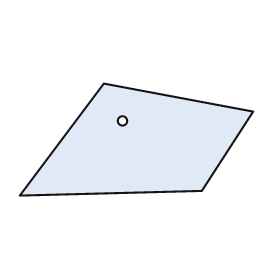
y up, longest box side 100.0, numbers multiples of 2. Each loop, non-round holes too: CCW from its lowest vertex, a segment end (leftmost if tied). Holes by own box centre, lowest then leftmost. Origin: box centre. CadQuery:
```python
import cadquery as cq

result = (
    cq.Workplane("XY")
    .moveTo(-50.0, -24.0)
    .lineTo(28.0, -22.0)
    .lineTo(50.0, 12.0)
    .lineTo(-14.0, 24.0)
    .close()
    .moveTo(-6.0, 8.0)
    .circle(2.0)
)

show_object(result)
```